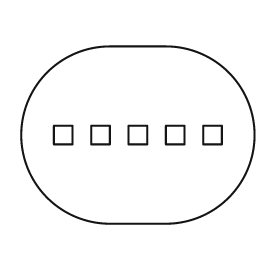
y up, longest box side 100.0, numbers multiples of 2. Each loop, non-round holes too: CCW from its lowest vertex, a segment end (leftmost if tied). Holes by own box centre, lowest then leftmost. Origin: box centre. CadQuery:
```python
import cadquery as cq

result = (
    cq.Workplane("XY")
    .moveTo(-12.0, -38.0)
    .lineTo(12.0, -38.0)
    .threePointArc((50.0, 0.0), (12.0, 38.0))
    .lineTo(-12.0, 38.0)
    .threePointArc((-50.0, 0.0), (-12.0, -38.0))
    .close()
    .moveTo(-36.0, -4.0)
    .lineTo(-28.0, -4.0)
    .lineTo(-28.0, 4.0)
    .lineTo(-36.0, 4.0)
    .close()
    .moveTo(-20.0, -4.0)
    .lineTo(-12.0, -4.0)
    .lineTo(-12.0, 4.0)
    .lineTo(-20.0, 4.0)
    .close()
    .moveTo(-4.0, -4.0)
    .lineTo(4.0, -4.0)
    .lineTo(4.0, 4.0)
    .lineTo(-4.0, 4.0)
    .close()
    .moveTo(12.0, -4.0)
    .lineTo(20.0, -4.0)
    .lineTo(20.0, 4.0)
    .lineTo(12.0, 4.0)
    .close()
    .moveTo(28.0, -4.0)
    .lineTo(36.0, -4.0)
    .lineTo(36.0, 4.0)
    .lineTo(28.0, 4.0)
    .close()
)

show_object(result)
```